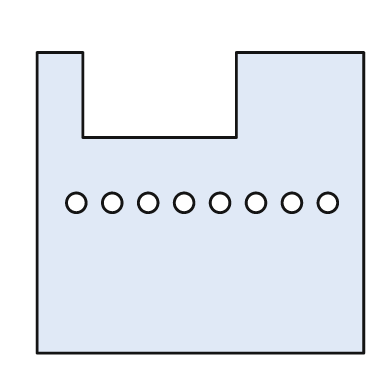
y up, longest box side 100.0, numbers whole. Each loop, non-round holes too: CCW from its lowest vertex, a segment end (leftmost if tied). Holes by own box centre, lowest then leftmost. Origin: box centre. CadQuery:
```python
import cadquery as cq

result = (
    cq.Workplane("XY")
    .moveTo(-50.0, -46.0)
    .lineTo(50.0, -46.0)
    .lineTo(50.0, 46.0)
    .lineTo(11.0, 46.0)
    .lineTo(11.0, 20.0)
    .lineTo(-36.0, 20.0)
    .lineTo(-36.0, 46.0)
    .lineTo(-50.0, 46.0)
    .close()
    .moveTo(-38.0, 0.0)
    .circle(3.0)
    .moveTo(-27.0, 0.0)
    .circle(3.0)
    .moveTo(-16.0, 0.0)
    .circle(3.0)
    .moveTo(-5.0, 0.0)
    .circle(3.0)
    .moveTo(6.0, 0.0)
    .circle(3.0)
    .moveTo(17.0, 0.0)
    .circle(3.0)
    .moveTo(28.0, 0.0)
    .circle(3.0)
    .moveTo(39.0, 0.0)
    .circle(3.0)
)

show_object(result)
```